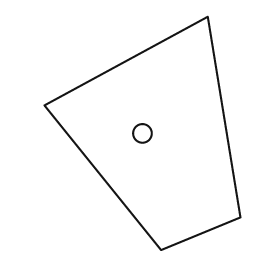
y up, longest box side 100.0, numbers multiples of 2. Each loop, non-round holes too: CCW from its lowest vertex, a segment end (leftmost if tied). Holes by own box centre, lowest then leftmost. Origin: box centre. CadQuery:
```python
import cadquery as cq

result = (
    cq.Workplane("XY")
    .moveTo(8.0, -50.0)
    .lineTo(42.0, -36.0)
    .lineTo(28.0, 50.0)
    .lineTo(-42.0, 12.0)
    .close()
    .moveTo(0.0, 0.0)
    .circle(4.0)
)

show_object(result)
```